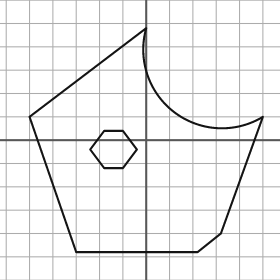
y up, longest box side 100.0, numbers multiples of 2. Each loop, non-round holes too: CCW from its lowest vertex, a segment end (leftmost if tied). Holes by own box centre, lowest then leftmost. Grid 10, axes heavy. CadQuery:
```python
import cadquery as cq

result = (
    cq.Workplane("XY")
    .moveTo(-30.0, -48.0)
    .lineTo(22.0, -48.0)
    .lineTo(32.0, -40.0)
    .lineTo(50.0, 10.0)
    .threePointArc((12.0, 12.0), (0.0, 48.0))
    .lineTo(-50.0, 10.0)
    .close()
    .moveTo(-18.0, -12.0)
    .lineTo(-10.0, -12.0)
    .lineTo(-4.0, -4.0)
    .lineTo(-10.0, 4.0)
    .lineTo(-18.0, 4.0)
    .lineTo(-24.0, -4.0)
    .close()
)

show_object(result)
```